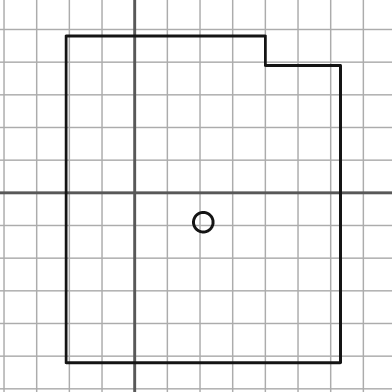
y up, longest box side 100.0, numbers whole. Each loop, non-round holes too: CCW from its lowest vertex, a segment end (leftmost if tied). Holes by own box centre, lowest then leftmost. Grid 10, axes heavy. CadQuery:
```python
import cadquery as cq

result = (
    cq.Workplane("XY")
    .moveTo(-21.0, -52.0)
    .lineTo(63.0, -52.0)
    .lineTo(63.0, 39.0)
    .lineTo(40.0, 39.0)
    .lineTo(40.0, 48.0)
    .lineTo(-21.0, 48.0)
    .close()
    .moveTo(21.0, -9.0)
    .circle(3.0)
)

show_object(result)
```